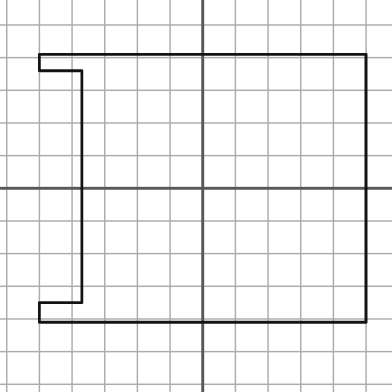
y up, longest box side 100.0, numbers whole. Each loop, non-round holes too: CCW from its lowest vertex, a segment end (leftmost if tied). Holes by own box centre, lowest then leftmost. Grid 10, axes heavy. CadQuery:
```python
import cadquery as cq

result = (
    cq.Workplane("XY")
    .moveTo(-50.0, -41.0)
    .lineTo(50.0, -41.0)
    .lineTo(50.0, 41.0)
    .lineTo(-50.0, 41.0)
    .lineTo(-50.0, 36.0)
    .lineTo(-37.0, 36.0)
    .lineTo(-37.0, -35.0)
    .lineTo(-50.0, -35.0)
    .close()
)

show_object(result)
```